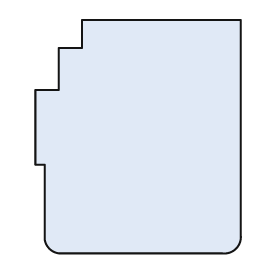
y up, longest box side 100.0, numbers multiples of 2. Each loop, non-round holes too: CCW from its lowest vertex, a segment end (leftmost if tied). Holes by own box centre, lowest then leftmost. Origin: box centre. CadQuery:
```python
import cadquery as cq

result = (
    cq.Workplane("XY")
    .moveTo(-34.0, -50.0)
    .lineTo(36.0, -50.0)
    .threePointArc((42.0, -48.0), (44.0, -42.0))
    .lineTo(44.0, 50.0)
    .lineTo(-24.0, 50.0)
    .lineTo(-24.0, 38.0)
    .lineTo(-34.0, 38.0)
    .lineTo(-34.0, 20.0)
    .lineTo(-44.0, 20.0)
    .lineTo(-44.0, -12.0)
    .lineTo(-40.0, -12.0)
    .lineTo(-40.0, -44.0)
    .threePointArc((-38.0, -48.0), (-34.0, -50.0))
    .close()
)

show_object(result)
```